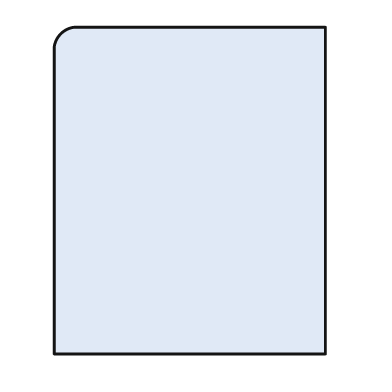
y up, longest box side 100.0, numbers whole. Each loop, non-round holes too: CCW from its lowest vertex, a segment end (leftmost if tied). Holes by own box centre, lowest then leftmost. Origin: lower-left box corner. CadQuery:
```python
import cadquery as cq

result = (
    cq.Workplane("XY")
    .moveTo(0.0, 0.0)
    .lineTo(83.0, 0.0)
    .lineTo(83.0, 100.0)
    .lineTo(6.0, 100.0)
    .threePointArc((2.0, 98.0), (0.0, 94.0))
    .close()
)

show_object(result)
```